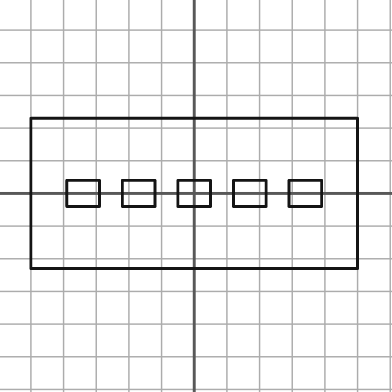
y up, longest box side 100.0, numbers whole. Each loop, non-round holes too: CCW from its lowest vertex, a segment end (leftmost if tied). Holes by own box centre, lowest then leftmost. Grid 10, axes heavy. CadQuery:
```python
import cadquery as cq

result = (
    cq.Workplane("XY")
    .moveTo(-50.0, -23.0)
    .lineTo(50.0, -23.0)
    .lineTo(50.0, 23.0)
    .lineTo(-50.0, 23.0)
    .close()
    .moveTo(-39.0, -4.0)
    .lineTo(-29.0, -4.0)
    .lineTo(-29.0, 4.0)
    .lineTo(-39.0, 4.0)
    .close()
    .moveTo(-22.0, -4.0)
    .lineTo(-12.0, -4.0)
    .lineTo(-12.0, 4.0)
    .lineTo(-22.0, 4.0)
    .close()
    .moveTo(-5.0, -4.0)
    .lineTo(5.0, -4.0)
    .lineTo(5.0, 4.0)
    .lineTo(-5.0, 4.0)
    .close()
    .moveTo(12.0, -4.0)
    .lineTo(22.0, -4.0)
    .lineTo(22.0, 4.0)
    .lineTo(12.0, 4.0)
    .close()
    .moveTo(29.0, -4.0)
    .lineTo(39.0, -4.0)
    .lineTo(39.0, 4.0)
    .lineTo(29.0, 4.0)
    .close()
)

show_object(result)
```